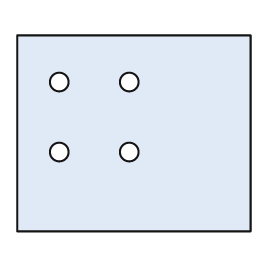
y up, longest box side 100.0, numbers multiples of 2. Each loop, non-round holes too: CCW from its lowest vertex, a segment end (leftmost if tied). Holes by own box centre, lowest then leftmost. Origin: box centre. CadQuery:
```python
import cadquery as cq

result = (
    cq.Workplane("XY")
    .moveTo(-50.0, -42.0)
    .lineTo(50.0, -42.0)
    .lineTo(50.0, 42.0)
    .lineTo(-50.0, 42.0)
    .close()
    .moveTo(-32.0, -8.0)
    .circle(4.0)
    .moveTo(-2.0, -8.0)
    .circle(4.0)
    .moveTo(-32.0, 22.0)
    .circle(4.0)
    .moveTo(-2.0, 22.0)
    .circle(4.0)
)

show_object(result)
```